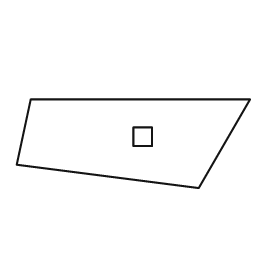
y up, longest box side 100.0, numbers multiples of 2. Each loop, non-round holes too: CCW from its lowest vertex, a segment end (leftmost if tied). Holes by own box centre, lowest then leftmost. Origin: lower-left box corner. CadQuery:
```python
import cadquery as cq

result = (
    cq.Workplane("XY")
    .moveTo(78.0, 0.0)
    .lineTo(100.0, 38.0)
    .lineTo(6.0, 38.0)
    .lineTo(0.0, 10.0)
    .close()
    .moveTo(50.0, 18.0)
    .lineTo(58.0, 18.0)
    .lineTo(58.0, 26.0)
    .lineTo(50.0, 26.0)
    .close()
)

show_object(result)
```